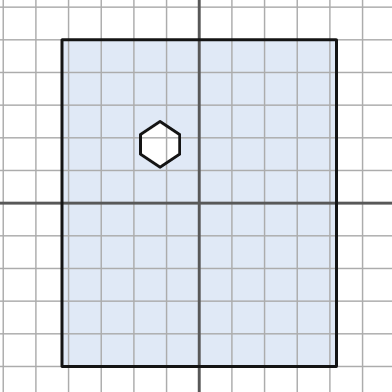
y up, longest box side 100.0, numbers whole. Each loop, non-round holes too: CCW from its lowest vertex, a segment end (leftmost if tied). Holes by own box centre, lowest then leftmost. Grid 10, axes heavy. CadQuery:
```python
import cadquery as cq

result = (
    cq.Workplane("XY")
    .moveTo(-42.0, -50.0)
    .lineTo(42.0, -50.0)
    .lineTo(42.0, 50.0)
    .lineTo(-42.0, 50.0)
    .close()
    .moveTo(-12.0, 11.0)
    .lineTo(-6.0, 15.0)
    .lineTo(-6.0, 21.0)
    .lineTo(-12.0, 25.0)
    .lineTo(-18.0, 21.0)
    .lineTo(-18.0, 15.0)
    .close()
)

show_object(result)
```